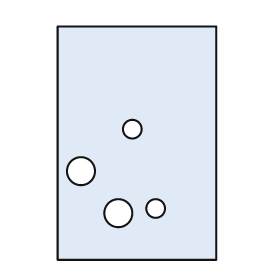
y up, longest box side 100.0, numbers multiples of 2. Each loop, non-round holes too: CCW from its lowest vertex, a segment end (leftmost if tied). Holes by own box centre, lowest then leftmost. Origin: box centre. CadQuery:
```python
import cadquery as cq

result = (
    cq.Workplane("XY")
    .moveTo(-34.0, -50.0)
    .lineTo(34.0, -50.0)
    .lineTo(34.0, 50.0)
    .lineTo(-34.0, 50.0)
    .close()
    .moveTo(-8.0, -30.0)
    .circle(6.0)
    .moveTo(8.0, -28.0)
    .circle(4.0)
    .moveTo(-24.0, -12.0)
    .circle(6.0)
    .moveTo(-2.0, 6.0)
    .circle(4.0)
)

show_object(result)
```